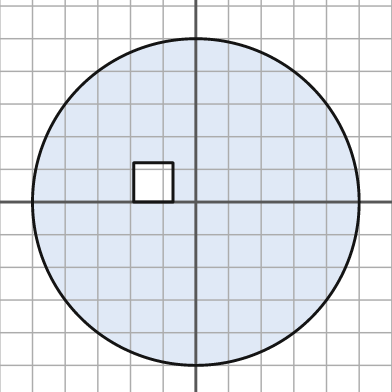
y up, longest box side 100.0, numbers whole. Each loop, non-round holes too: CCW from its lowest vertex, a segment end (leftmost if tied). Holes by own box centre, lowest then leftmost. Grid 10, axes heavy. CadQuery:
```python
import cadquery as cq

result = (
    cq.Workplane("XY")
    .moveTo(0.0, 0.0)
    .circle(50.0)
    .moveTo(-19.0, 0.0)
    .lineTo(-7.0, 0.0)
    .lineTo(-7.0, 12.0)
    .lineTo(-19.0, 12.0)
    .close()
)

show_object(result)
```